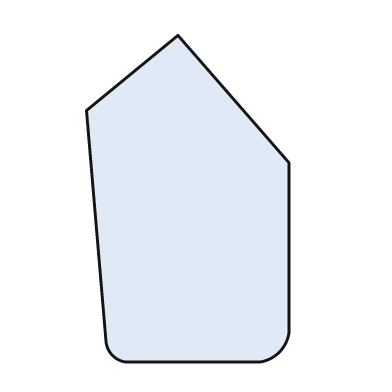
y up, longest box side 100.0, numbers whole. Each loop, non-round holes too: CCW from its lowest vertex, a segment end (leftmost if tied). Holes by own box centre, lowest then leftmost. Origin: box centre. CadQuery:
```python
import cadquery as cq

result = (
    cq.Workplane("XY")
    .moveTo(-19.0, -50.0)
    .lineTo(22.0, -50.0)
    .threePointArc((28.0, -47.0), (31.0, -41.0))
    .lineTo(31.0, 11.0)
    .lineTo(-3.0, 50.0)
    .lineTo(-31.0, 27.0)
    .lineTo(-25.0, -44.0)
    .threePointArc((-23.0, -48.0), (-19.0, -50.0))
    .close()
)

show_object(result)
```